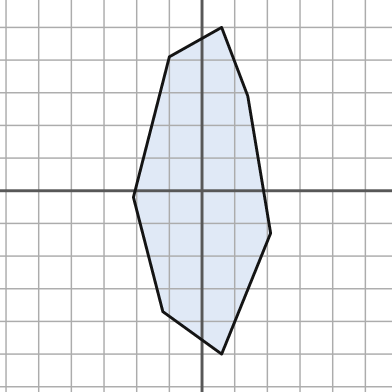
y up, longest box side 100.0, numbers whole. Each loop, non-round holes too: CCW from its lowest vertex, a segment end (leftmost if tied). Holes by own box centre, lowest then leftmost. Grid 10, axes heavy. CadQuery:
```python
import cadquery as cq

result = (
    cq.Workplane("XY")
    .moveTo(6.0, -50.0)
    .lineTo(21.0, -13.0)
    .lineTo(14.0, 29.0)
    .lineTo(6.0, 50.0)
    .lineTo(-10.0, 41.0)
    .lineTo(-21.0, -2.0)
    .lineTo(-12.0, -37.0)
    .close()
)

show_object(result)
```